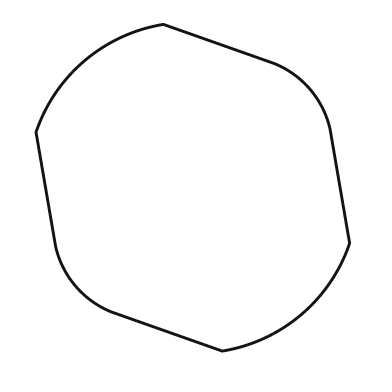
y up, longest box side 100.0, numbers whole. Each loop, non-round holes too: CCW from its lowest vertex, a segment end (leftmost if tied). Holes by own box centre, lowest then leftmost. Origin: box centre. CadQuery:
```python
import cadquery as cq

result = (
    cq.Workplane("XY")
    .moveTo(9.0, -50.0)
    .threePointArc((33.0, -39.0), (48.0, -17.0))
    .lineTo(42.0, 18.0)
    .threePointArc((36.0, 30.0), (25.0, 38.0))
    .lineTo(-9.0, 50.0)
    .threePointArc((-33.0, 39.0), (-48.0, 17.0))
    .lineTo(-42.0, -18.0)
    .threePointArc((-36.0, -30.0), (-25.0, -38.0))
    .close()
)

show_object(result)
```